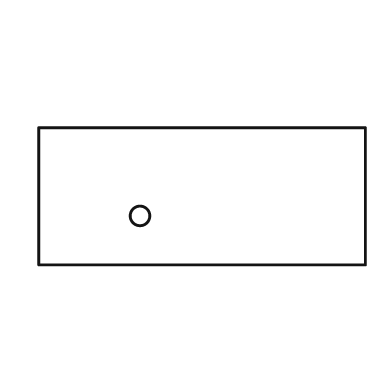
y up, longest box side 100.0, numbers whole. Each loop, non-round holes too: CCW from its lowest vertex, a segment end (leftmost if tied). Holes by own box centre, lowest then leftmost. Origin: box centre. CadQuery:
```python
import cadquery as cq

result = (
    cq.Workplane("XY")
    .moveTo(-50.0, -21.0)
    .lineTo(50.0, -21.0)
    .lineTo(50.0, 21.0)
    .lineTo(-50.0, 21.0)
    .close()
    .moveTo(-19.0, -6.0)
    .circle(3.0)
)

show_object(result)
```